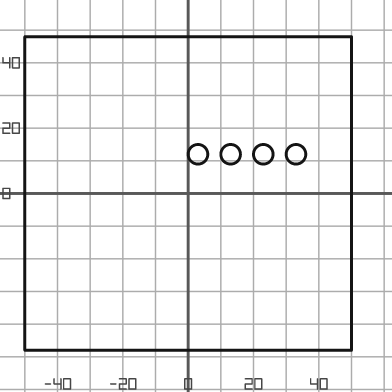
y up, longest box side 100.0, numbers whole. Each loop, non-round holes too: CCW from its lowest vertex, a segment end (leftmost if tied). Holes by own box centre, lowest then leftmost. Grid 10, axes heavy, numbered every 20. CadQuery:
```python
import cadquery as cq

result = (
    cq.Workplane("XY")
    .moveTo(-50.0, -48.0)
    .lineTo(50.0, -48.0)
    .lineTo(50.0, 48.0)
    .lineTo(-50.0, 48.0)
    .close()
    .moveTo(3.0, 12.0)
    .circle(3.0)
    .moveTo(13.0, 12.0)
    .circle(3.0)
    .moveTo(23.0, 12.0)
    .circle(3.0)
    .moveTo(33.0, 12.0)
    .circle(3.0)
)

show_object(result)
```